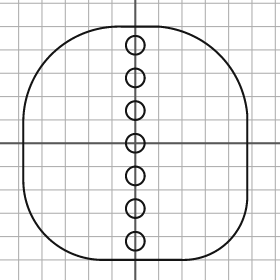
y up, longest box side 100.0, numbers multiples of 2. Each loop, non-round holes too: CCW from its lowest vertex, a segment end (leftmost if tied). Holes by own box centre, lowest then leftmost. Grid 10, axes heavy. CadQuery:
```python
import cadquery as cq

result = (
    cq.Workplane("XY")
    .moveTo(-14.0, -50.0)
    .lineTo(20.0, -50.0)
    .threePointArc((40.0, -42.0), (48.0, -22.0))
    .lineTo(48.0, 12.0)
    .threePointArc((36.0, 38.0), (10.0, 50.0))
    .lineTo(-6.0, 50.0)
    .threePointArc((-36.0, 38.0), (-48.0, 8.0))
    .lineTo(-48.0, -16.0)
    .threePointArc((-38.0, -40.0), (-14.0, -50.0))
    .close()
    .moveTo(0.0, -42.0)
    .circle(4.0)
    .moveTo(0.0, -28.0)
    .circle(4.0)
    .moveTo(0.0, -14.0)
    .circle(4.0)
    .moveTo(0.0, 0.0)
    .circle(4.0)
    .moveTo(0.0, 14.0)
    .circle(4.0)
    .moveTo(0.0, 28.0)
    .circle(4.0)
    .moveTo(0.0, 42.0)
    .circle(4.0)
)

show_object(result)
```